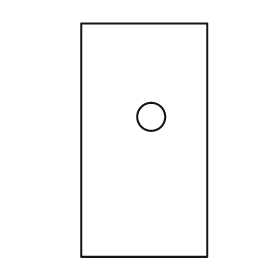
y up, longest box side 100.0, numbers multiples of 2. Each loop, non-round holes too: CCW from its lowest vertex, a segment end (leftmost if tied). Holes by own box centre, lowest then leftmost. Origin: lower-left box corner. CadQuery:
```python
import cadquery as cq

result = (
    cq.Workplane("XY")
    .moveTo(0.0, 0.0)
    .lineTo(54.0, 0.0)
    .lineTo(54.0, 100.0)
    .lineTo(0.0, 100.0)
    .close()
    .moveTo(30.0, 60.0)
    .circle(6.0)
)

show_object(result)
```